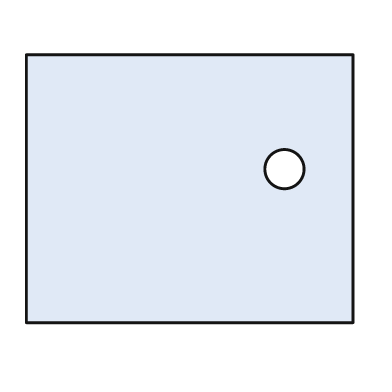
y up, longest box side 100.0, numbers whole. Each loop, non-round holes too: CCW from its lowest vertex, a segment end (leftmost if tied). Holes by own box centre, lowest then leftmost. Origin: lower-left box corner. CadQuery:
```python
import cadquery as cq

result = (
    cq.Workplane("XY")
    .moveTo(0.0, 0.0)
    .lineTo(100.0, 0.0)
    .lineTo(100.0, 82.0)
    .lineTo(0.0, 82.0)
    .close()
    .moveTo(79.0, 47.0)
    .circle(6.0)
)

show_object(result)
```